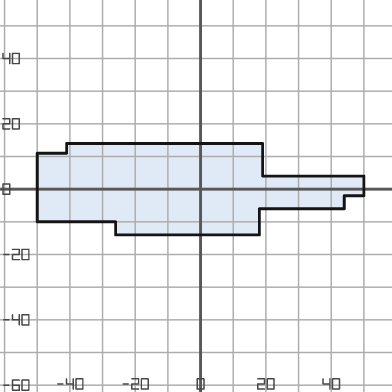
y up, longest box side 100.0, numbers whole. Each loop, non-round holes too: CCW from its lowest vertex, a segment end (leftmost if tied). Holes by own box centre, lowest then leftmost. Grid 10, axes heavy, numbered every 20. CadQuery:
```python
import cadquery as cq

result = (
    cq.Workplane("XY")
    .moveTo(-26.0, -14.0)
    .lineTo(18.0, -14.0)
    .lineTo(18.0, -6.0)
    .lineTo(44.0, -6.0)
    .lineTo(44.0, -2.0)
    .lineTo(50.0, -2.0)
    .lineTo(50.0, 4.0)
    .lineTo(19.0, 4.0)
    .lineTo(19.0, 14.0)
    .lineTo(-41.0, 14.0)
    .lineTo(-41.0, 11.0)
    .lineTo(-50.0, 11.0)
    .lineTo(-50.0, -10.0)
    .lineTo(-26.0, -10.0)
    .close()
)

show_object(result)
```